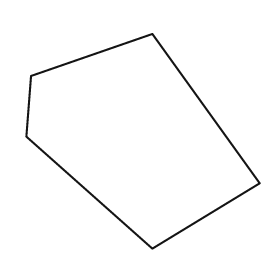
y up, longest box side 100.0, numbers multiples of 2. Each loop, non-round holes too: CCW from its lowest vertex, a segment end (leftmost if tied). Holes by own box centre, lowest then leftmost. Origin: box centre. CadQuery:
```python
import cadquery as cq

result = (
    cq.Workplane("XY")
    .moveTo(4.0, -46.0)
    .lineTo(50.0, -18.0)
    .lineTo(4.0, 46.0)
    .lineTo(-48.0, 28.0)
    .lineTo(-50.0, 2.0)
    .close()
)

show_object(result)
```